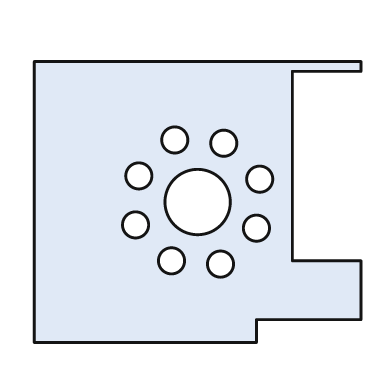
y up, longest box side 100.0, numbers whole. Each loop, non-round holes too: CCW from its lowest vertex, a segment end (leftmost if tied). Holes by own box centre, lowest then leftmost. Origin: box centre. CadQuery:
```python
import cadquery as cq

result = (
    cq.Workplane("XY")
    .moveTo(-50.0, -43.0)
    .lineTo(18.0, -43.0)
    .lineTo(18.0, -36.0)
    .lineTo(50.0, -36.0)
    .lineTo(50.0, -18.0)
    .lineTo(29.0, -18.0)
    .lineTo(29.0, 40.0)
    .lineTo(50.0, 40.0)
    .lineTo(50.0, 43.0)
    .lineTo(-50.0, 43.0)
    .close()
    .moveTo(7.0, -19.0)
    .circle(4.0)
    .moveTo(-8.0, -18.0)
    .circle(4.0)
    .moveTo(18.0, -8.0)
    .circle(4.0)
    .moveTo(-19.0, -7.0)
    .circle(4.0)
    .moveTo(0.0, 0.0)
    .circle(10.0)
    .moveTo(19.0, 7.0)
    .circle(4.0)
    .moveTo(-18.0, 8.0)
    .circle(4.0)
    .moveTo(8.0, 18.0)
    .circle(4.0)
    .moveTo(-7.0, 19.0)
    .circle(4.0)
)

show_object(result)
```